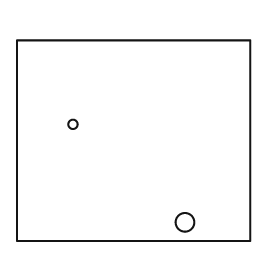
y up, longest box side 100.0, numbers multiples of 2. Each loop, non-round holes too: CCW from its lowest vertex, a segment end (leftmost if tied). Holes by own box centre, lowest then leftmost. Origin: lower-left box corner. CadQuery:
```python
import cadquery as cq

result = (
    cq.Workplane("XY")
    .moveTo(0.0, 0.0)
    .lineTo(100.0, 0.0)
    .lineTo(100.0, 86.0)
    .lineTo(0.0, 86.0)
    .close()
    .moveTo(72.0, 8.0)
    .circle(4.0)
    .moveTo(24.0, 50.0)
    .circle(2.0)
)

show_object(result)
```